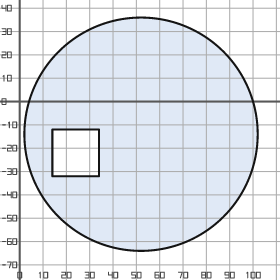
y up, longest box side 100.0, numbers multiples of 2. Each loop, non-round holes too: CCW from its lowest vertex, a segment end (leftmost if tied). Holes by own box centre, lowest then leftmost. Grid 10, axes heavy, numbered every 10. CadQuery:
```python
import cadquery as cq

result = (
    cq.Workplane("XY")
    .moveTo(52.0, -14.0)
    .circle(50.0)
    .moveTo(14.0, -32.0)
    .lineTo(34.0, -32.0)
    .lineTo(34.0, -12.0)
    .lineTo(14.0, -12.0)
    .close()
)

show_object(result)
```